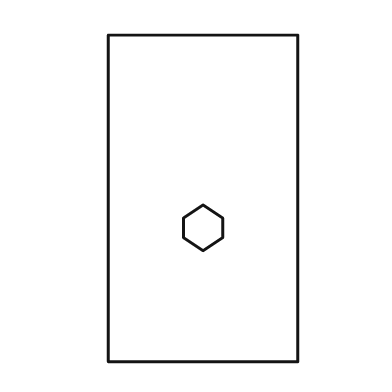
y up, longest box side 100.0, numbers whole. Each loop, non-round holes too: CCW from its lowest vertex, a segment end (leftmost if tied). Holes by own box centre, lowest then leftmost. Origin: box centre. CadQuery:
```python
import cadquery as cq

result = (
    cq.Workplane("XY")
    .moveTo(-29.0, -50.0)
    .lineTo(29.0, -50.0)
    .lineTo(29.0, 50.0)
    .lineTo(-29.0, 50.0)
    .close()
    .moveTo(0.0, -16.0)
    .lineTo(6.0, -12.0)
    .lineTo(6.0, -6.0)
    .lineTo(0.0, -2.0)
    .lineTo(-6.0, -6.0)
    .lineTo(-6.0, -12.0)
    .close()
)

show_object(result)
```